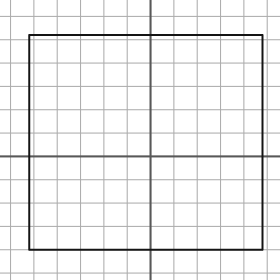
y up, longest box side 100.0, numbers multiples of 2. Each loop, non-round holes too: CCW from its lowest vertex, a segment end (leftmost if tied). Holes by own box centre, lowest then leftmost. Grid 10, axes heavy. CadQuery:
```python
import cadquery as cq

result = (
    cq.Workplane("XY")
    .moveTo(-52.0, -40.0)
    .lineTo(48.0, -40.0)
    .lineTo(48.0, 52.0)
    .lineTo(-52.0, 52.0)
    .close()
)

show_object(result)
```